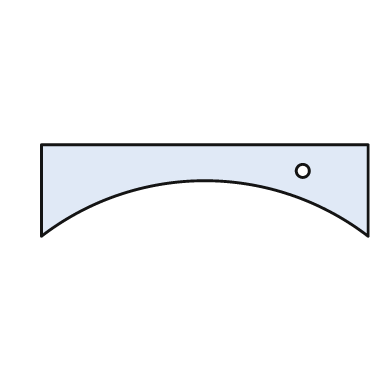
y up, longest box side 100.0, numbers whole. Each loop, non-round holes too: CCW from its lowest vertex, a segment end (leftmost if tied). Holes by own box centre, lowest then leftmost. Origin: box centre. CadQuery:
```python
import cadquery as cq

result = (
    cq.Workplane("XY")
    .moveTo(-50.0, -14.0)
    .threePointArc((0.0, 3.0), (50.0, -14.0))
    .lineTo(50.0, 14.0)
    .lineTo(-50.0, 14.0)
    .close()
    .moveTo(30.0, 6.0)
    .circle(2.0)
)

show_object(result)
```